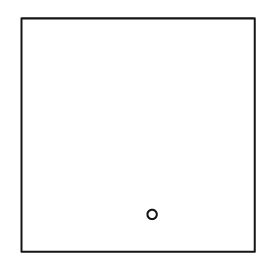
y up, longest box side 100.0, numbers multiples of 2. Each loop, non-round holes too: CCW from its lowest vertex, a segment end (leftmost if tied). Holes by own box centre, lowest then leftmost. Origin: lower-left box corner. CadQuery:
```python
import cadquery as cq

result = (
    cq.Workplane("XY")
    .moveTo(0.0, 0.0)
    .lineTo(100.0, 0.0)
    .lineTo(100.0, 100.0)
    .lineTo(0.0, 100.0)
    .close()
    .moveTo(56.0, 16.0)
    .circle(2.0)
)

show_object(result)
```